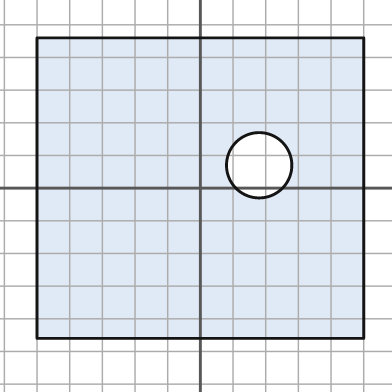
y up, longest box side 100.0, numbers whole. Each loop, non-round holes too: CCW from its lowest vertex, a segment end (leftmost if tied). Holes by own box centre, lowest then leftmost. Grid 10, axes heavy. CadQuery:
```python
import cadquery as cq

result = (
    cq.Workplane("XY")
    .moveTo(-50.0, -46.0)
    .lineTo(50.0, -46.0)
    .lineTo(50.0, 46.0)
    .lineTo(-50.0, 46.0)
    .close()
    .moveTo(18.0, 7.0)
    .circle(10.0)
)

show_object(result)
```